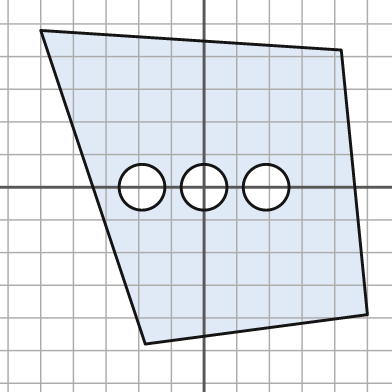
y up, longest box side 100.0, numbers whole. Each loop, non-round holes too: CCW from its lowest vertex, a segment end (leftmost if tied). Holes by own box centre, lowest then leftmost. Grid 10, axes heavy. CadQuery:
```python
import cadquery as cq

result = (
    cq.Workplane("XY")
    .moveTo(-18.0, -48.0)
    .lineTo(50.0, -39.0)
    .lineTo(42.0, 42.0)
    .lineTo(-50.0, 48.0)
    .close()
    .moveTo(-19.0, 0.0)
    .circle(7.0)
    .moveTo(0.0, 0.0)
    .circle(7.0)
    .moveTo(19.0, 0.0)
    .circle(7.0)
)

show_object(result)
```